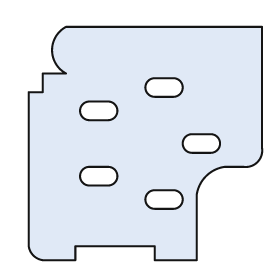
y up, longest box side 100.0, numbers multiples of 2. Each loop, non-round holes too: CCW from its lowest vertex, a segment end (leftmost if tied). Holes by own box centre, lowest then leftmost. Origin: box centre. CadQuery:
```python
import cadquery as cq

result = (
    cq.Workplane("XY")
    .moveTo(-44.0, -50.0)
    .lineTo(-30.0, -50.0)
    .lineTo(-30.0, -44.0)
    .lineTo(4.0, -44.0)
    .lineTo(4.0, -50.0)
    .lineTo(22.0, -50.0)
    .lineTo(22.0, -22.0)
    .threePointArc((26.0, -14.0), (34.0, -10.0))
    .lineTo(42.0, -10.0)
    .threePointArc((48.0, -8.0), (50.0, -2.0))
    .lineTo(50.0, 50.0)
    .lineTo(-34.0, 50.0)
    .threePointArc((-40.0, 40.0), (-34.0, 30.0))
    .lineTo(-44.0, 30.0)
    .lineTo(-44.0, 22.0)
    .lineTo(-50.0, 22.0)
    .lineTo(-50.0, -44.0)
    .threePointArc((-48.0, -48.0), (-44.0, -50.0))
    .close()
    .moveTo(4.0, -28.0)
    .lineTo(12.0, -28.0)
    .threePointArc((16.0, -24.0), (12.0, -20.0))
    .lineTo(4.0, -20.0)
    .threePointArc((0.0, -24.0), (4.0, -28.0))
    .close()
    .moveTo(-24.0, -18.0)
    .lineTo(-16.0, -18.0)
    .threePointArc((-12.0, -14.0), (-16.0, -10.0))
    .lineTo(-24.0, -10.0)
    .threePointArc((-28.0, -14.0), (-24.0, -18.0))
    .close()
    .moveTo(20.0, -4.0)
    .lineTo(28.0, -4.0)
    .threePointArc((32.0, 0.0), (28.0, 4.0))
    .lineTo(20.0, 4.0)
    .threePointArc((16.0, 0.0), (20.0, -4.0))
    .close()
    .moveTo(-24.0, 10.0)
    .lineTo(-16.0, 10.0)
    .threePointArc((-12.0, 14.0), (-16.0, 18.0))
    .lineTo(-24.0, 18.0)
    .threePointArc((-28.0, 14.0), (-24.0, 10.0))
    .close()
    .moveTo(4.0, 20.0)
    .lineTo(12.0, 20.0)
    .threePointArc((16.0, 24.0), (12.0, 28.0))
    .lineTo(4.0, 28.0)
    .threePointArc((0.0, 24.0), (4.0, 20.0))
    .close()
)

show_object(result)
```